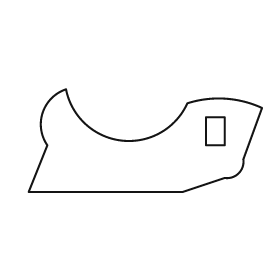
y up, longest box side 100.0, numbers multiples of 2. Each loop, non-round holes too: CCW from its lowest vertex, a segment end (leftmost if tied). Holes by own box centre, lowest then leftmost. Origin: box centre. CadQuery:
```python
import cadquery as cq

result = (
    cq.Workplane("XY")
    .moveTo(-50.0, -22.0)
    .lineTo(16.0, -22.0)
    .lineTo(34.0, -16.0)
    .threePointArc((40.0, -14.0), (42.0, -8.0))
    .lineTo(50.0, 14.0)
    .threePointArc((34.0, 18.0), (18.0, 16.0))
    .threePointArc((-10.0, 0.0), (-34.0, 22.0))
    .threePointArc((-44.0, 12.0), (-42.0, -2.0))
    .close()
    .moveTo(26.0, -2.0)
    .lineTo(34.0, -2.0)
    .lineTo(34.0, 10.0)
    .lineTo(26.0, 10.0)
    .close()
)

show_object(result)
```